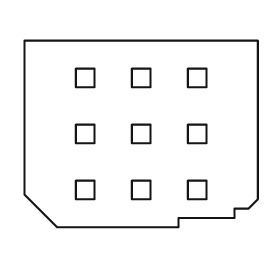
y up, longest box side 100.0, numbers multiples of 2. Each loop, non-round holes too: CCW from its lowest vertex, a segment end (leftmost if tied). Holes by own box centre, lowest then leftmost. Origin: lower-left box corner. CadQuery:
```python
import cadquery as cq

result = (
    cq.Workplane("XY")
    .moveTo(14.0, 0.0)
    .lineTo(66.0, 0.0)
    .lineTo(66.0, 4.0)
    .lineTo(90.0, 4.0)
    .lineTo(90.0, 8.0)
    .lineTo(96.0, 8.0)
    .lineTo(100.0, 12.0)
    .lineTo(100.0, 80.0)
    .lineTo(0.0, 80.0)
    .lineTo(0.0, 14.0)
    .close()
    .moveTo(22.0, 12.0)
    .lineTo(30.0, 12.0)
    .lineTo(30.0, 20.0)
    .lineTo(22.0, 20.0)
    .close()
    .moveTo(46.0, 12.0)
    .lineTo(54.0, 12.0)
    .lineTo(54.0, 20.0)
    .lineTo(46.0, 20.0)
    .close()
    .moveTo(70.0, 12.0)
    .lineTo(78.0, 12.0)
    .lineTo(78.0, 20.0)
    .lineTo(70.0, 20.0)
    .close()
    .moveTo(22.0, 36.0)
    .lineTo(30.0, 36.0)
    .lineTo(30.0, 44.0)
    .lineTo(22.0, 44.0)
    .close()
    .moveTo(46.0, 36.0)
    .lineTo(54.0, 36.0)
    .lineTo(54.0, 44.0)
    .lineTo(46.0, 44.0)
    .close()
    .moveTo(70.0, 36.0)
    .lineTo(78.0, 36.0)
    .lineTo(78.0, 44.0)
    .lineTo(70.0, 44.0)
    .close()
    .moveTo(22.0, 60.0)
    .lineTo(30.0, 60.0)
    .lineTo(30.0, 68.0)
    .lineTo(22.0, 68.0)
    .close()
    .moveTo(46.0, 60.0)
    .lineTo(54.0, 60.0)
    .lineTo(54.0, 68.0)
    .lineTo(46.0, 68.0)
    .close()
    .moveTo(70.0, 60.0)
    .lineTo(78.0, 60.0)
    .lineTo(78.0, 68.0)
    .lineTo(70.0, 68.0)
    .close()
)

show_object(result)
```